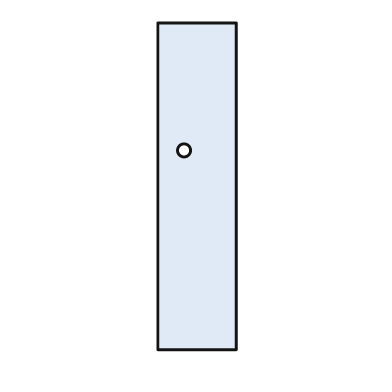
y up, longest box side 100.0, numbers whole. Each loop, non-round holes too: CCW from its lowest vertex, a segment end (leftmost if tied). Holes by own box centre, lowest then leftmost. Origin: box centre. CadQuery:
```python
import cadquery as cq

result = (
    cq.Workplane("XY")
    .moveTo(-12.0, -50.0)
    .lineTo(12.0, -50.0)
    .lineTo(12.0, 50.0)
    .lineTo(-12.0, 50.0)
    .close()
    .moveTo(-4.0, 11.0)
    .circle(2.0)
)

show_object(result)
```